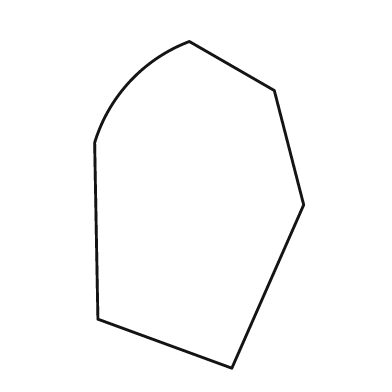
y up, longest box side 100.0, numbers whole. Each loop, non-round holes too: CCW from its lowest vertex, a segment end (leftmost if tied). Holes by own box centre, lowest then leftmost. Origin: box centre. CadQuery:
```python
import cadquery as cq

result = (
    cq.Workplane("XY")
    .moveTo(10.0, -50.0)
    .lineTo(32.0, 0.0)
    .lineTo(23.0, 35.0)
    .lineTo(-3.0, 50.0)
    .threePointArc((-21.0, 38.0), (-32.0, 19.0))
    .lineTo(-31.0, -35.0)
    .close()
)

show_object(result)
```